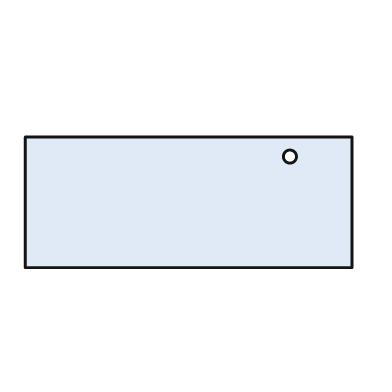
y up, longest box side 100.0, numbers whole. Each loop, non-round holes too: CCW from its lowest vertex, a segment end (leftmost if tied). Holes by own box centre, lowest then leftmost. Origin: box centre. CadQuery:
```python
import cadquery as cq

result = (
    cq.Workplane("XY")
    .moveTo(-50.0, -20.0)
    .lineTo(50.0, -20.0)
    .lineTo(50.0, 20.0)
    .lineTo(-50.0, 20.0)
    .close()
    .moveTo(31.0, 14.0)
    .circle(2.0)
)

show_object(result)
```